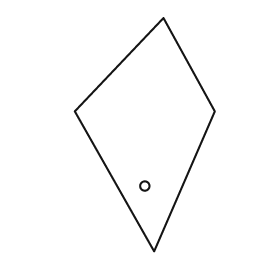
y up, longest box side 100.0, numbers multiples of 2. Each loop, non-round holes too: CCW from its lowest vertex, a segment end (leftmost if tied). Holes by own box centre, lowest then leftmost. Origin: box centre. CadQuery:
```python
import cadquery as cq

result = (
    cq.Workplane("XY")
    .moveTo(4.0, -50.0)
    .lineTo(30.0, 10.0)
    .lineTo(8.0, 50.0)
    .lineTo(-30.0, 10.0)
    .close()
    .moveTo(0.0, -22.0)
    .circle(2.0)
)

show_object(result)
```